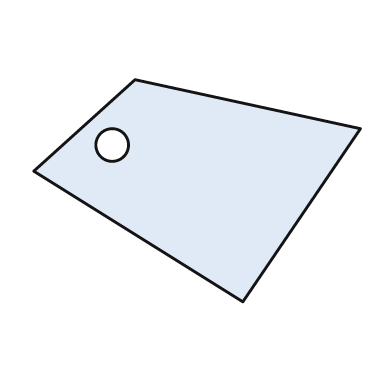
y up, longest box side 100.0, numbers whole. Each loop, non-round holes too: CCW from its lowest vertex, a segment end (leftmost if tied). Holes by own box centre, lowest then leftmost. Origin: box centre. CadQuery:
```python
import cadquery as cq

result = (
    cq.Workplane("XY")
    .moveTo(14.0, -34.0)
    .lineTo(50.0, 19.0)
    .lineTo(-19.0, 34.0)
    .lineTo(-50.0, 6.0)
    .close()
    .moveTo(-26.0, 14.0)
    .circle(5.0)
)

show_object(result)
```